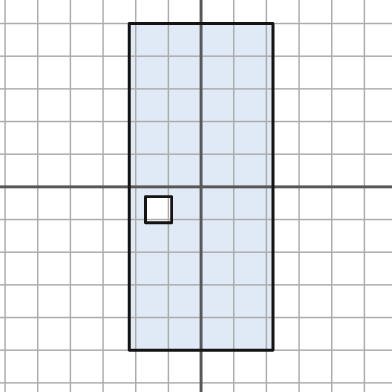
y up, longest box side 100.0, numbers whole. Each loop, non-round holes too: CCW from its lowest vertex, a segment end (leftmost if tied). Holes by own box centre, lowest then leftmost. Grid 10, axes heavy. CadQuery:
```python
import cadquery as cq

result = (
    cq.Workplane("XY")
    .moveTo(-22.0, -50.0)
    .lineTo(22.0, -50.0)
    .lineTo(22.0, 50.0)
    .lineTo(-22.0, 50.0)
    .close()
    .moveTo(-17.0, -11.0)
    .lineTo(-9.0, -11.0)
    .lineTo(-9.0, -3.0)
    .lineTo(-17.0, -3.0)
    .close()
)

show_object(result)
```